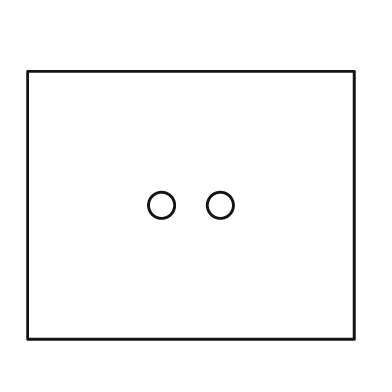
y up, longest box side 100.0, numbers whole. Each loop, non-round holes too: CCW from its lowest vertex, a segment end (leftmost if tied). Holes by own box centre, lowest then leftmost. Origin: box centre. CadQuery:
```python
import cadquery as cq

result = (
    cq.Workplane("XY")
    .moveTo(-50.0, -41.0)
    .lineTo(50.0, -41.0)
    .lineTo(50.0, 41.0)
    .lineTo(-50.0, 41.0)
    .close()
    .moveTo(-9.0, 0.0)
    .circle(4.0)
    .moveTo(9.0, 0.0)
    .circle(4.0)
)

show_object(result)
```